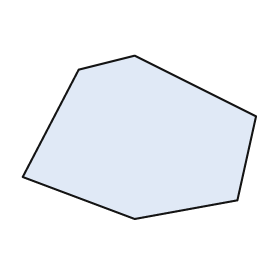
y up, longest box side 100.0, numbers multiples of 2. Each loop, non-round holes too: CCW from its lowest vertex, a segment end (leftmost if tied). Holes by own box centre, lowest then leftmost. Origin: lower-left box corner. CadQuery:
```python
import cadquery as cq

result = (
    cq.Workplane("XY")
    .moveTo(48.0, 0.0)
    .lineTo(92.0, 8.0)
    .lineTo(100.0, 44.0)
    .lineTo(48.0, 70.0)
    .lineTo(24.0, 64.0)
    .lineTo(0.0, 18.0)
    .close()
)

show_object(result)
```